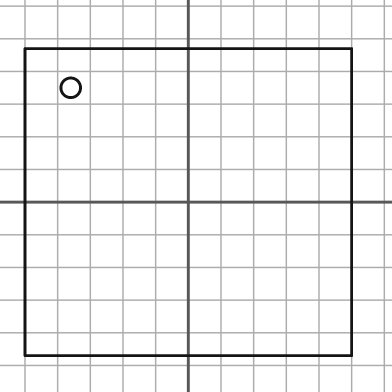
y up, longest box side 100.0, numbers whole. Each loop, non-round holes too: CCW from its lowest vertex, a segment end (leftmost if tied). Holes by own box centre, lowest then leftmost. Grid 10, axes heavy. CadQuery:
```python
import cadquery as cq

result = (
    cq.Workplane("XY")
    .moveTo(-50.0, -47.0)
    .lineTo(50.0, -47.0)
    .lineTo(50.0, 47.0)
    .lineTo(-50.0, 47.0)
    .close()
    .moveTo(-36.0, 35.0)
    .circle(3.0)
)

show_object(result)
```